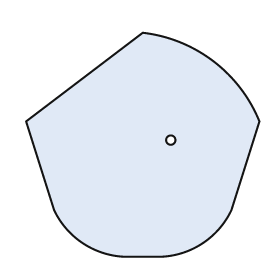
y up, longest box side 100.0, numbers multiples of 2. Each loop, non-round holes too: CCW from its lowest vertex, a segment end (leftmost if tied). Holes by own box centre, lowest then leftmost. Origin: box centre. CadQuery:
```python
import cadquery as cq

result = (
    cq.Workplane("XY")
    .moveTo(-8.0, -48.0)
    .lineTo(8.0, -48.0)
    .threePointArc((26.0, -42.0), (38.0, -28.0))
    .lineTo(50.0, 10.0)
    .threePointArc((30.0, 36.0), (0.0, 48.0))
    .lineTo(-50.0, 10.0)
    .lineTo(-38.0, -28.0)
    .threePointArc((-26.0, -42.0), (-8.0, -48.0))
    .close()
    .moveTo(12.0, 2.0)
    .circle(2.0)
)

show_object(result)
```